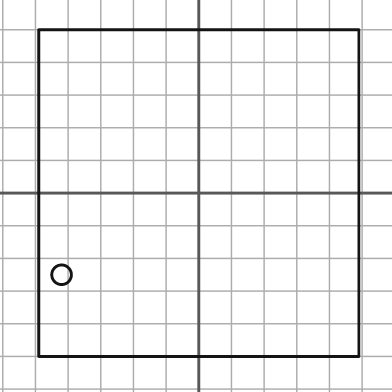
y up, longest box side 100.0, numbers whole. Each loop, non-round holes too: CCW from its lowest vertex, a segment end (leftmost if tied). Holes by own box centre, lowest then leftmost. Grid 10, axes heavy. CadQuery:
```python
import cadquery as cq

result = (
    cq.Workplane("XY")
    .moveTo(-49.0, -50.0)
    .lineTo(49.0, -50.0)
    .lineTo(49.0, 50.0)
    .lineTo(-49.0, 50.0)
    .close()
    .moveTo(-42.0, -25.0)
    .circle(3.0)
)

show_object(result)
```